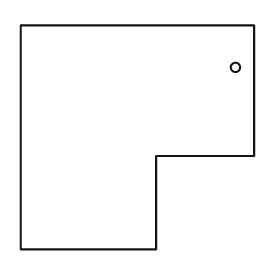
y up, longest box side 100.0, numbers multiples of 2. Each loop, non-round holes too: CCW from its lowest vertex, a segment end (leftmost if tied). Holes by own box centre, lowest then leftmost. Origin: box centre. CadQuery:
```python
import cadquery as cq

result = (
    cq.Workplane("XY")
    .moveTo(-50.0, -48.0)
    .lineTo(8.0, -48.0)
    .lineTo(8.0, -8.0)
    .lineTo(50.0, -8.0)
    .lineTo(50.0, 48.0)
    .lineTo(-50.0, 48.0)
    .close()
    .moveTo(42.0, 30.0)
    .circle(2.0)
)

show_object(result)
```